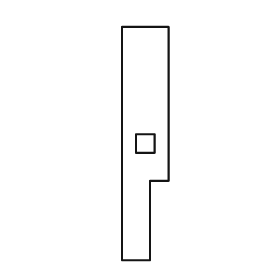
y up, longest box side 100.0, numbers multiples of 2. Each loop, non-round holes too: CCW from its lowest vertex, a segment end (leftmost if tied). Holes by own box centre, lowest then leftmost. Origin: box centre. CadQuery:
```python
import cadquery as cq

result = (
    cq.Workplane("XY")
    .moveTo(-10.0, -50.0)
    .lineTo(2.0, -50.0)
    .lineTo(2.0, -16.0)
    .lineTo(10.0, -16.0)
    .lineTo(10.0, 50.0)
    .lineTo(-10.0, 50.0)
    .close()
    .moveTo(-4.0, -4.0)
    .lineTo(4.0, -4.0)
    .lineTo(4.0, 4.0)
    .lineTo(-4.0, 4.0)
    .close()
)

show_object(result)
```